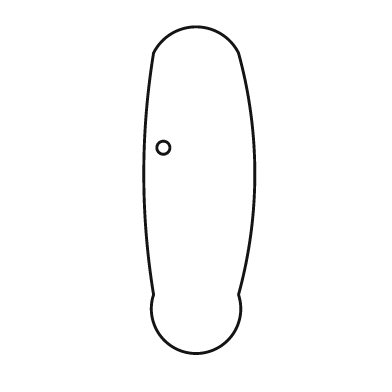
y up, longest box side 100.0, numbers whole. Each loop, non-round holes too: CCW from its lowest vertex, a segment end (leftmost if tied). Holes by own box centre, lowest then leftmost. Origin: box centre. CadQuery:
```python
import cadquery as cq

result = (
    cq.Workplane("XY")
    .moveTo(-14.0, -32.0)
    .threePointArc((-1.0, -50.0), (12.0, -32.0))
    .threePointArc((17.0, 5.0), (12.0, 42.0))
    .threePointArc((-1.0, 50.0), (-14.0, 42.0))
    .threePointArc((-17.0, 5.0), (-14.0, -32.0))
    .close()
    .moveTo(-11.0, 13.0)
    .circle(2.0)
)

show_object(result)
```